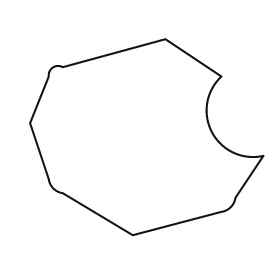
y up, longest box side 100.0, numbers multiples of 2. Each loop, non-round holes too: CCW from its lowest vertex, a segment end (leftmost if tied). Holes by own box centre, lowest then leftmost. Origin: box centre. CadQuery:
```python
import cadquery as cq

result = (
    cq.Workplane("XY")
    .moveTo(-6.0, -42.0)
    .lineTo(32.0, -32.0)
    .threePointArc((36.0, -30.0), (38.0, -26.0))
    .lineTo(50.0, -8.0)
    .threePointArc((28.0, 2.0), (32.0, 26.0))
    .lineTo(8.0, 42.0)
    .lineTo(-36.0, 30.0)
    .threePointArc((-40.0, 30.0), (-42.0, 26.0))
    .lineTo(-50.0, 6.0)
    .lineTo(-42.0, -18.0)
    .threePointArc((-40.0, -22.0), (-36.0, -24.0))
    .close()
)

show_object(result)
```